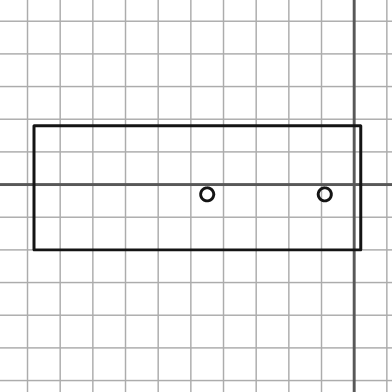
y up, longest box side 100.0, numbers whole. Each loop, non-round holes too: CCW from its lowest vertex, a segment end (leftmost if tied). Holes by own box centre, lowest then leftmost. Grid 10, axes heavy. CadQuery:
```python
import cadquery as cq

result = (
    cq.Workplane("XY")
    .moveTo(-98.0, -20.0)
    .lineTo(2.0, -20.0)
    .lineTo(2.0, 18.0)
    .lineTo(-98.0, 18.0)
    .close()
    .moveTo(-45.0, -3.0)
    .circle(2.0)
    .moveTo(-9.0, -3.0)
    .circle(2.0)
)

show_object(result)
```